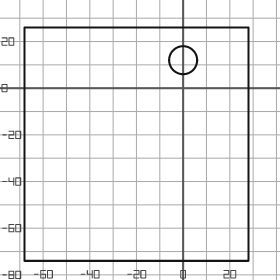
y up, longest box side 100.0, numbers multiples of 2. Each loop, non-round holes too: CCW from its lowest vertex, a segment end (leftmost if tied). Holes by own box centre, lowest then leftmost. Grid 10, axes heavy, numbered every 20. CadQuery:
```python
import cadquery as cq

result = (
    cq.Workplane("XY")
    .moveTo(-68.0, -74.0)
    .lineTo(28.0, -74.0)
    .lineTo(28.0, 26.0)
    .lineTo(-68.0, 26.0)
    .close()
    .moveTo(0.0, 12.0)
    .circle(6.0)
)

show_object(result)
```